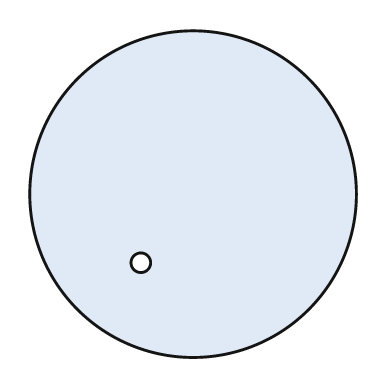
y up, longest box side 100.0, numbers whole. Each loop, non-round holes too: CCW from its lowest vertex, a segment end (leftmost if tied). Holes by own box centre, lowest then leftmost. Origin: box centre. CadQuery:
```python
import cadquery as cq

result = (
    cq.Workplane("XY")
    .moveTo(0.0, 0.0)
    .circle(50.0)
    .moveTo(-16.0, -21.0)
    .circle(3.0)
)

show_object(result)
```